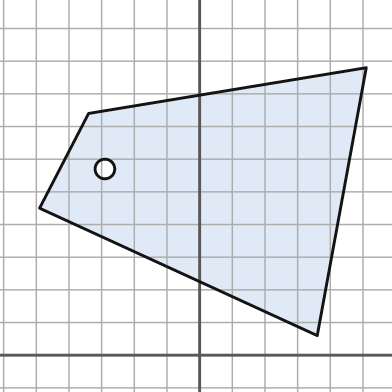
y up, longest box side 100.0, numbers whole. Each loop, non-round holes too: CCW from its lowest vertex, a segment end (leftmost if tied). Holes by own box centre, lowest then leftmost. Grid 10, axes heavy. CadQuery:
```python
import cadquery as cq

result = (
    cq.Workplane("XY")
    .moveTo(36.0, 6.0)
    .lineTo(51.0, 88.0)
    .lineTo(-34.0, 74.0)
    .lineTo(-49.0, 45.0)
    .close()
    .moveTo(-29.0, 57.0)
    .circle(3.0)
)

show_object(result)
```